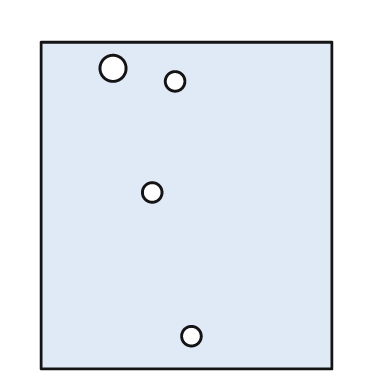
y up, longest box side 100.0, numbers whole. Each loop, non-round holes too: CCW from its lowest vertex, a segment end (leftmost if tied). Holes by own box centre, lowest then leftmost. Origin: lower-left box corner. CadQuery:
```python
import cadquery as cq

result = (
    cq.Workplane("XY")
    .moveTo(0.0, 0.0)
    .lineTo(89.0, 0.0)
    .lineTo(89.0, 100.0)
    .lineTo(0.0, 100.0)
    .close()
    .moveTo(46.0, 10.0)
    .circle(3.0)
    .moveTo(34.0, 54.0)
    .circle(3.0)
    .moveTo(41.0, 88.0)
    .circle(3.0)
    .moveTo(22.0, 92.0)
    .circle(4.0)
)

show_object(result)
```